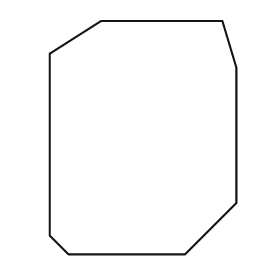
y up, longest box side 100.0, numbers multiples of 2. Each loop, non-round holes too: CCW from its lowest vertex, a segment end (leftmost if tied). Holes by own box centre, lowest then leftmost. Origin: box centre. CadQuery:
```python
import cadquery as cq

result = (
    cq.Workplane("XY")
    .moveTo(-32.0, -50.0)
    .lineTo(18.0, -50.0)
    .lineTo(40.0, -28.0)
    .lineTo(40.0, 30.0)
    .lineTo(34.0, 50.0)
    .lineTo(-18.0, 50.0)
    .lineTo(-40.0, 36.0)
    .lineTo(-40.0, -42.0)
    .close()
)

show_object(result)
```